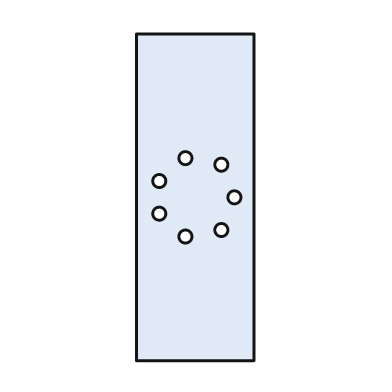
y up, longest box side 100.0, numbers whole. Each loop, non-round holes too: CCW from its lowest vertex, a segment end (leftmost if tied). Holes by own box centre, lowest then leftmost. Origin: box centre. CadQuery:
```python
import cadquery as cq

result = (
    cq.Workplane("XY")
    .moveTo(-18.0, -50.0)
    .lineTo(18.0, -50.0)
    .lineTo(18.0, 50.0)
    .lineTo(-18.0, 50.0)
    .close()
    .moveTo(-3.0, -12.0)
    .circle(2.0)
    .moveTo(8.0, -10.0)
    .circle(2.0)
    .moveTo(-11.0, -5.0)
    .circle(2.0)
    .moveTo(12.0, 0.0)
    .circle(2.0)
    .moveTo(-11.0, 5.0)
    .circle(2.0)
    .moveTo(8.0, 10.0)
    .circle(2.0)
    .moveTo(-3.0, 12.0)
    .circle(2.0)
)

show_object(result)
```